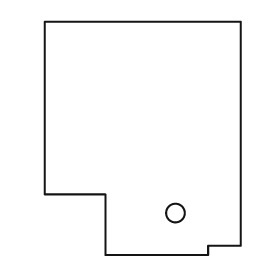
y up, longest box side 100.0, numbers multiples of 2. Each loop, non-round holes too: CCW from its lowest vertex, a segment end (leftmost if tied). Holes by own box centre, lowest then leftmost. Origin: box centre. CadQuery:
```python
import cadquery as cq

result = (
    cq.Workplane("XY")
    .moveTo(-16.0, -50.0)
    .lineTo(28.0, -50.0)
    .lineTo(28.0, -46.0)
    .lineTo(42.0, -46.0)
    .lineTo(42.0, 50.0)
    .lineTo(-42.0, 50.0)
    .lineTo(-42.0, -24.0)
    .lineTo(-16.0, -24.0)
    .close()
    .moveTo(14.0, -32.0)
    .circle(4.0)
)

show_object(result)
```